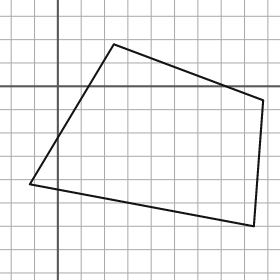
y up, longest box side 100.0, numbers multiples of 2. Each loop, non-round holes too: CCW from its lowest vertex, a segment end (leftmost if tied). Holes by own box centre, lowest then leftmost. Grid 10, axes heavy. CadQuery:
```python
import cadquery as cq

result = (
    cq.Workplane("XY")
    .moveTo(84.0, -60.0)
    .lineTo(88.0, -6.0)
    .lineTo(24.0, 18.0)
    .lineTo(-12.0, -42.0)
    .close()
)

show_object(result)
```